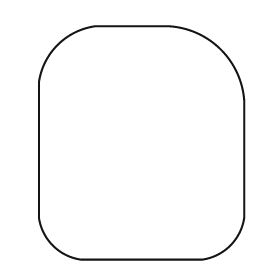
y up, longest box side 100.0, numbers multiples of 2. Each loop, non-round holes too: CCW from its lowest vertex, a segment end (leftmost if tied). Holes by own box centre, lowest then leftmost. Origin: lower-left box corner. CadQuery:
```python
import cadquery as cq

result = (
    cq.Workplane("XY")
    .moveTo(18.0, 0.0)
    .lineTo(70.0, 0.0)
    .threePointArc((82.0, 6.0), (88.0, 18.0))
    .lineTo(88.0, 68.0)
    .threePointArc((78.0, 90.0), (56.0, 100.0))
    .lineTo(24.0, 100.0)
    .threePointArc((8.0, 92.0), (0.0, 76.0))
    .lineTo(0.0, 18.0)
    .threePointArc((6.0, 6.0), (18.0, 0.0))
    .close()
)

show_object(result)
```